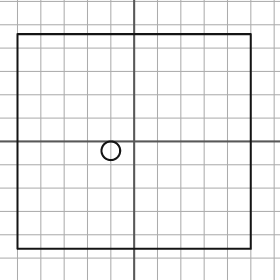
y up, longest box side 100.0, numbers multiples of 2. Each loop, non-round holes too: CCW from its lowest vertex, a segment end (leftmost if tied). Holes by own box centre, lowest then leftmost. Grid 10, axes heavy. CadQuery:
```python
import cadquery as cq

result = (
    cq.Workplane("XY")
    .moveTo(-50.0, -46.0)
    .lineTo(50.0, -46.0)
    .lineTo(50.0, 46.0)
    .lineTo(-50.0, 46.0)
    .close()
    .moveTo(-10.0, -4.0)
    .circle(4.0)
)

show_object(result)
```